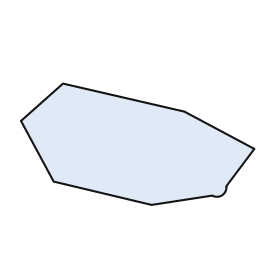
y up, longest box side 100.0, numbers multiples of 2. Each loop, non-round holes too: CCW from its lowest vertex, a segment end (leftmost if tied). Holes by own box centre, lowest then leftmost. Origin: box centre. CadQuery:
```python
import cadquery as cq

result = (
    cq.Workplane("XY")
    .moveTo(6.0, -26.0)
    .lineTo(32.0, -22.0)
    .threePointArc((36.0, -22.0), (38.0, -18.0))
    .lineTo(50.0, -2.0)
    .lineTo(20.0, 14.0)
    .lineTo(-32.0, 26.0)
    .lineTo(-50.0, 10.0)
    .lineTo(-36.0, -16.0)
    .close()
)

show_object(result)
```